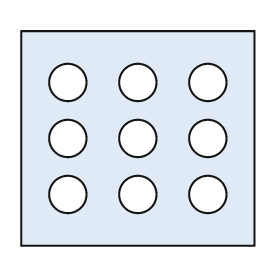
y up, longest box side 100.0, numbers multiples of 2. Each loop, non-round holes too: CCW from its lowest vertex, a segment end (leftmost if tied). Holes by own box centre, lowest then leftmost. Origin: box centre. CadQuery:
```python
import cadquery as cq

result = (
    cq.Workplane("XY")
    .moveTo(-50.0, -46.0)
    .lineTo(50.0, -46.0)
    .lineTo(50.0, 46.0)
    .lineTo(-50.0, 46.0)
    .close()
    .moveTo(-30.0, -24.0)
    .circle(8.0)
    .moveTo(0.0, -24.0)
    .circle(8.0)
    .moveTo(30.0, -24.0)
    .circle(8.0)
    .moveTo(-30.0, 0.0)
    .circle(8.0)
    .moveTo(0.0, 0.0)
    .circle(8.0)
    .moveTo(30.0, 0.0)
    .circle(8.0)
    .moveTo(-30.0, 24.0)
    .circle(8.0)
    .moveTo(0.0, 24.0)
    .circle(8.0)
    .moveTo(30.0, 24.0)
    .circle(8.0)
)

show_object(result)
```